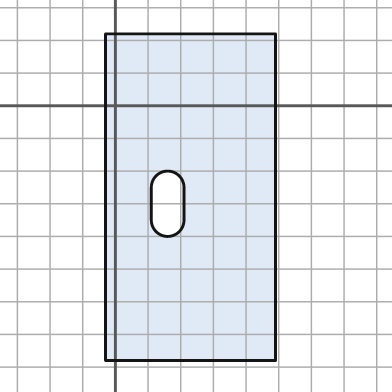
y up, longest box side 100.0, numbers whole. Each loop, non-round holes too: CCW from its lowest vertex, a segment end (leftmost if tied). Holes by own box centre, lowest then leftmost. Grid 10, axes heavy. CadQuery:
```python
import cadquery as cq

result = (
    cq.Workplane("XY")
    .moveTo(-3.0, -78.0)
    .lineTo(49.0, -78.0)
    .lineTo(49.0, 22.0)
    .lineTo(-3.0, 22.0)
    .close()
    .moveTo(11.0, -35.0)
    .threePointArc((16.0, -40.0), (21.0, -35.0))
    .lineTo(21.0, -25.0)
    .threePointArc((16.0, -20.0), (11.0, -25.0))
    .close()
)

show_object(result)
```